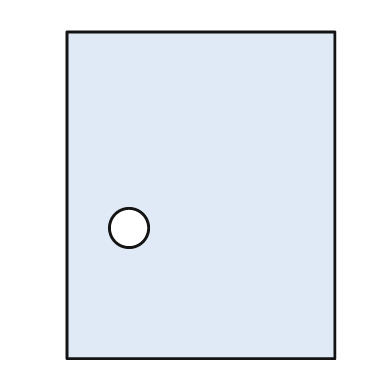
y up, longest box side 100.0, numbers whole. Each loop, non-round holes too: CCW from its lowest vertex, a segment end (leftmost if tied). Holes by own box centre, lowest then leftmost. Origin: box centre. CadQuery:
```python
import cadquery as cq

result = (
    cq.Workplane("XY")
    .moveTo(-41.0, -50.0)
    .lineTo(41.0, -50.0)
    .lineTo(41.0, 50.0)
    .lineTo(-41.0, 50.0)
    .close()
    .moveTo(-22.0, -10.0)
    .circle(6.0)
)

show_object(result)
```